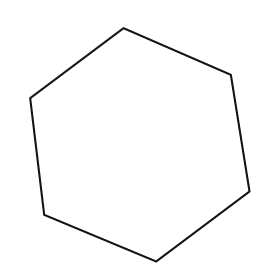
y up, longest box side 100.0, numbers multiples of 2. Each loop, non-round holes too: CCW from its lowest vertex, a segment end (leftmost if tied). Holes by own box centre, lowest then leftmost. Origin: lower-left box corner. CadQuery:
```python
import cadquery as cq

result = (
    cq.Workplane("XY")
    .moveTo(54.0, 0.0)
    .lineTo(94.0, 30.0)
    .lineTo(86.0, 80.0)
    .lineTo(40.0, 100.0)
    .lineTo(0.0, 70.0)
    .lineTo(6.0, 20.0)
    .close()
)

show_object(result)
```